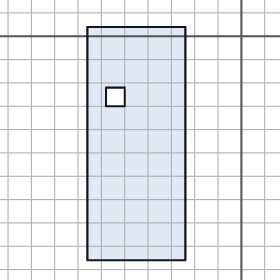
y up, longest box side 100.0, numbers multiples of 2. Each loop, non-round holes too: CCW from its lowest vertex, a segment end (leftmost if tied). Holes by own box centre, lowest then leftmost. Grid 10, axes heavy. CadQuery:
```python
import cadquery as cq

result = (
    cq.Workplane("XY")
    .moveTo(-66.0, -96.0)
    .lineTo(-24.0, -96.0)
    .lineTo(-24.0, 4.0)
    .lineTo(-66.0, 4.0)
    .close()
    .moveTo(-58.0, -30.0)
    .lineTo(-50.0, -30.0)
    .lineTo(-50.0, -22.0)
    .lineTo(-58.0, -22.0)
    .close()
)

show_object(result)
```